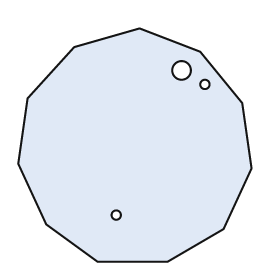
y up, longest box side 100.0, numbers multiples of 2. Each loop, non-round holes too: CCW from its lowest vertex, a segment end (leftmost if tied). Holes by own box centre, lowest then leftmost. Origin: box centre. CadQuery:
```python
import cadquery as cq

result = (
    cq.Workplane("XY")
    .moveTo(-16.0, -50.0)
    .lineTo(14.0, -50.0)
    .lineTo(38.0, -36.0)
    .lineTo(50.0, -10.0)
    .lineTo(46.0, 18.0)
    .lineTo(28.0, 40.0)
    .lineTo(2.0, 50.0)
    .lineTo(-26.0, 42.0)
    .lineTo(-46.0, 20.0)
    .lineTo(-50.0, -8.0)
    .lineTo(-38.0, -34.0)
    .close()
    .moveTo(-8.0, -30.0)
    .circle(2.0)
    .moveTo(30.0, 26.0)
    .circle(2.0)
    .moveTo(20.0, 32.0)
    .circle(4.0)
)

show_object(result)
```